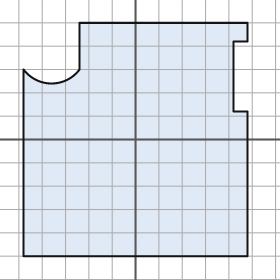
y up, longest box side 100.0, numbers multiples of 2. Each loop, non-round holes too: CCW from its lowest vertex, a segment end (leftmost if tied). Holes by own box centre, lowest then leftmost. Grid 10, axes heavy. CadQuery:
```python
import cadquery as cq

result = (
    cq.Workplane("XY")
    .moveTo(-48.0, -50.0)
    .lineTo(48.0, -50.0)
    .lineTo(48.0, 12.0)
    .lineTo(42.0, 12.0)
    .lineTo(42.0, 42.0)
    .lineTo(48.0, 42.0)
    .lineTo(48.0, 50.0)
    .lineTo(-24.0, 50.0)
    .lineTo(-24.0, 30.0)
    .threePointArc((-36.0, 24.0), (-48.0, 30.0))
    .close()
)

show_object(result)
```